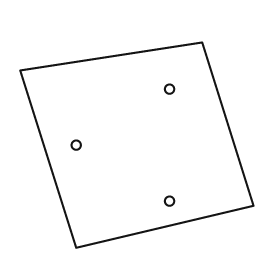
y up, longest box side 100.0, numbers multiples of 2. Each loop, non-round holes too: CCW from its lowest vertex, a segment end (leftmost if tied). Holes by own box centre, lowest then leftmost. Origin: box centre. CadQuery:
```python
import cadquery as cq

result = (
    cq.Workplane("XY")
    .moveTo(-26.0, -44.0)
    .lineTo(50.0, -26.0)
    .lineTo(28.0, 44.0)
    .lineTo(-50.0, 32.0)
    .close()
    .moveTo(14.0, -24.0)
    .circle(2.0)
    .moveTo(-26.0, 0.0)
    .circle(2.0)
    .moveTo(14.0, 24.0)
    .circle(2.0)
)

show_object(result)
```